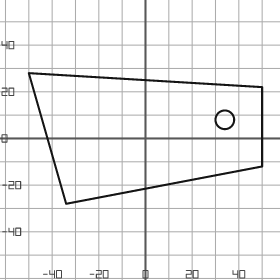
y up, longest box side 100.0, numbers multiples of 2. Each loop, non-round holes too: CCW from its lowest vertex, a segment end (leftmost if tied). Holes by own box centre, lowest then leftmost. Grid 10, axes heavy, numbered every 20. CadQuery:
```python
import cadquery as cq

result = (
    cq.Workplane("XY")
    .moveTo(-34.0, -28.0)
    .lineTo(50.0, -12.0)
    .lineTo(50.0, 22.0)
    .lineTo(-50.0, 28.0)
    .close()
    .moveTo(34.0, 8.0)
    .circle(4.0)
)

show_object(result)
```